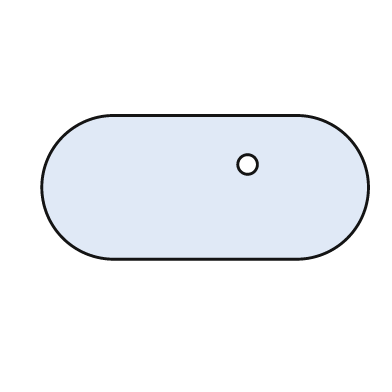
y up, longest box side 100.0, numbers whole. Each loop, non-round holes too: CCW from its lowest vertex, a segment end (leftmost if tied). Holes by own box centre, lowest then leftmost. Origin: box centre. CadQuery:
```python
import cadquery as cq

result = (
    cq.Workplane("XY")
    .moveTo(-28.0, -22.0)
    .lineTo(28.0, -22.0)
    .threePointArc((50.0, 0.0), (28.0, 22.0))
    .lineTo(-28.0, 22.0)
    .threePointArc((-50.0, 0.0), (-28.0, -22.0))
    .close()
    .moveTo(13.0, 7.0)
    .circle(3.0)
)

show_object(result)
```